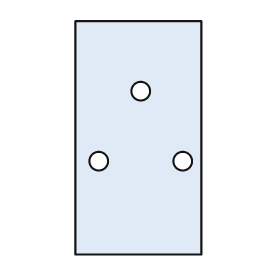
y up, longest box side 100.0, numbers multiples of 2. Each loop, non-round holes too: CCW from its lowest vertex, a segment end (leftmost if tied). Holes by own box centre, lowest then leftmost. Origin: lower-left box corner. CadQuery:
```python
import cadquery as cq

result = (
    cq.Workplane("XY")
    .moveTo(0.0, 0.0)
    .lineTo(54.0, 0.0)
    .lineTo(54.0, 100.0)
    .lineTo(0.0, 100.0)
    .close()
    .moveTo(10.0, 40.0)
    .circle(4.0)
    .moveTo(46.0, 40.0)
    .circle(4.0)
    .moveTo(28.0, 70.0)
    .circle(4.0)
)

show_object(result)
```